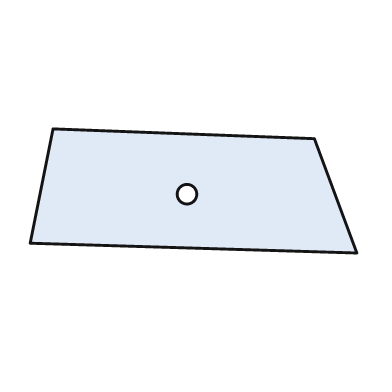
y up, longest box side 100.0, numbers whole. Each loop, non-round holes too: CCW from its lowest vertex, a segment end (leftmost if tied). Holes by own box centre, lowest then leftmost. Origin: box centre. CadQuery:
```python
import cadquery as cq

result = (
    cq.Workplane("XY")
    .moveTo(50.0, -19.0)
    .lineTo(37.0, 16.0)
    .lineTo(-43.0, 19.0)
    .lineTo(-50.0, -16.0)
    .close()
    .moveTo(-2.0, -1.0)
    .circle(3.0)
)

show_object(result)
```